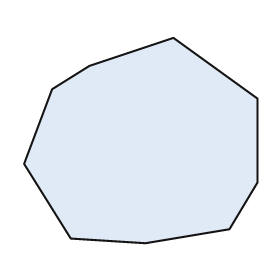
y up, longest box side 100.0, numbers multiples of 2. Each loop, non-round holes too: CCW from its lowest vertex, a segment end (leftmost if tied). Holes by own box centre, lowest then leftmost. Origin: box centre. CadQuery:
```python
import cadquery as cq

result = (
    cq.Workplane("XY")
    .moveTo(2.0, -44.0)
    .lineTo(38.0, -38.0)
    .lineTo(50.0, -18.0)
    .lineTo(50.0, 18.0)
    .lineTo(14.0, 44.0)
    .lineTo(-22.0, 32.0)
    .lineTo(-38.0, 22.0)
    .lineTo(-50.0, -10.0)
    .lineTo(-30.0, -42.0)
    .close()
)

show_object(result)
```